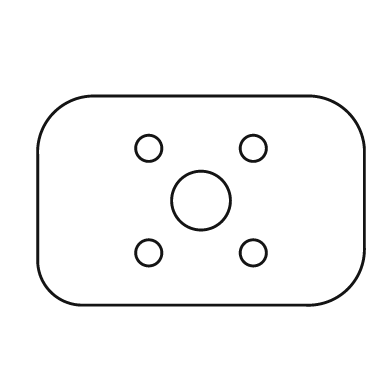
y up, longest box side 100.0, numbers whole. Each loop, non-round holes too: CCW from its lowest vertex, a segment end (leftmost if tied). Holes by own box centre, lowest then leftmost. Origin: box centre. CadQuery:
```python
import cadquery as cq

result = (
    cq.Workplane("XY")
    .moveTo(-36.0, -32.0)
    .lineTo(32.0, -32.0)
    .threePointArc((45.0, -27.0), (50.0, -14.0))
    .lineTo(50.0, 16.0)
    .threePointArc((45.0, 27.0), (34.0, 32.0))
    .lineTo(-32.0, 32.0)
    .threePointArc((-45.0, 27.0), (-50.0, 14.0))
    .lineTo(-50.0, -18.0)
    .threePointArc((-46.0, -28.0), (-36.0, -32.0))
    .close()
    .moveTo(-16.0, -16.0)
    .circle(4.0)
    .moveTo(16.0, -16.0)
    .circle(4.0)
    .moveTo(0.0, 0.0)
    .circle(9.0)
    .moveTo(-16.0, 16.0)
    .circle(4.0)
    .moveTo(16.0, 16.0)
    .circle(4.0)
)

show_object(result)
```